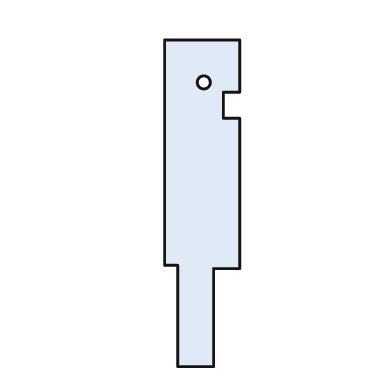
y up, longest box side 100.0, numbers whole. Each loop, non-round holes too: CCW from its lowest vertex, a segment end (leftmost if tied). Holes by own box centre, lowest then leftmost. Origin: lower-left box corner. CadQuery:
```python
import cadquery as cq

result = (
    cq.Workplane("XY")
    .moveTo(4.0, 0.0)
    .lineTo(15.0, 0.0)
    .lineTo(15.0, 30.0)
    .lineTo(23.0, 30.0)
    .lineTo(23.0, 76.0)
    .lineTo(18.0, 76.0)
    .lineTo(18.0, 84.0)
    .lineTo(23.0, 84.0)
    .lineTo(23.0, 100.0)
    .lineTo(0.0, 100.0)
    .lineTo(0.0, 31.0)
    .lineTo(4.0, 31.0)
    .close()
    .moveTo(12.0, 87.0)
    .circle(2.0)
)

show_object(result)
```